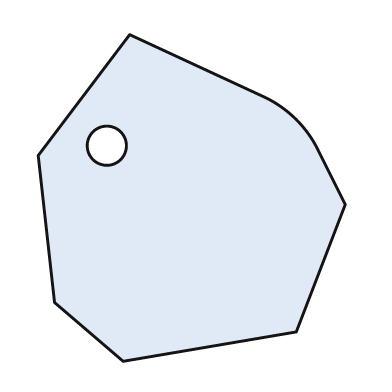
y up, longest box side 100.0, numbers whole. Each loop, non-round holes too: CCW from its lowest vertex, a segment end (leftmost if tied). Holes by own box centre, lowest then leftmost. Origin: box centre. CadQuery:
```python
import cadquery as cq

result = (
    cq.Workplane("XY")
    .moveTo(-21.0, -50.0)
    .lineTo(32.0, -41.0)
    .lineTo(47.0, -2.0)
    .lineTo(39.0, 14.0)
    .threePointArc((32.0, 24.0), (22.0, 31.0))
    .lineTo(-19.0, 50.0)
    .lineTo(-47.0, 13.0)
    .lineTo(-42.0, -32.0)
    .close()
    .moveTo(-26.0, 16.0)
    .circle(6.0)
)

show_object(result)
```